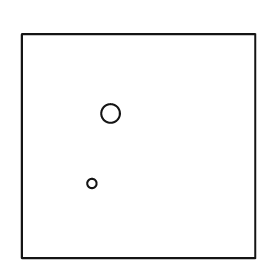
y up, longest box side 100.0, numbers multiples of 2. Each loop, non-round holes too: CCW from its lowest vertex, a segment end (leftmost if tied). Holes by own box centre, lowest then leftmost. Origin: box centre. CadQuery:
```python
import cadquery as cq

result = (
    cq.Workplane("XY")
    .moveTo(-50.0, -48.0)
    .lineTo(50.0, -48.0)
    .lineTo(50.0, 48.0)
    .lineTo(-50.0, 48.0)
    .close()
    .moveTo(-20.0, -16.0)
    .circle(2.0)
    .moveTo(-12.0, 14.0)
    .circle(4.0)
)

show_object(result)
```